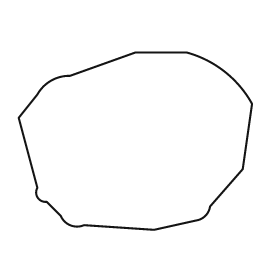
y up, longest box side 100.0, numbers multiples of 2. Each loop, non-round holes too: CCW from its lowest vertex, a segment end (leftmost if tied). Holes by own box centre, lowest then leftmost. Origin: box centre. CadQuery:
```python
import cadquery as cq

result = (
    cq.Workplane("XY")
    .moveTo(8.0, -38.0)
    .lineTo(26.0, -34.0)
    .threePointArc((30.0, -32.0), (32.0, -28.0))
    .lineTo(46.0, -12.0)
    .lineTo(50.0, 16.0)
    .threePointArc((38.0, 30.0), (22.0, 38.0))
    .lineTo(0.0, 38.0)
    .lineTo(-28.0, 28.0)
    .threePointArc((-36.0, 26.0), (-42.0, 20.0))
    .lineTo(-50.0, 10.0)
    .lineTo(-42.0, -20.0)
    .threePointArc((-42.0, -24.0), (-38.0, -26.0))
    .lineTo(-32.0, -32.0)
    .threePointArc((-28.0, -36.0), (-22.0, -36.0))
    .close()
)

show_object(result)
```